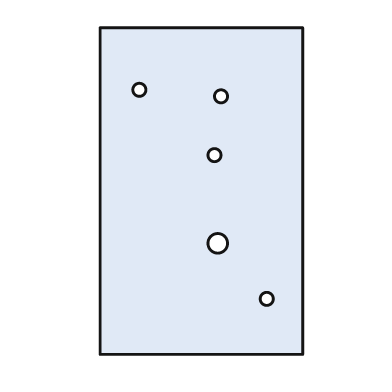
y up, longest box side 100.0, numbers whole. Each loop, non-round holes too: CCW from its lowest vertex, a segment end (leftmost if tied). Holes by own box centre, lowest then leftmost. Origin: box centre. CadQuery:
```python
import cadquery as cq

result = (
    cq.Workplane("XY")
    .moveTo(-31.0, -50.0)
    .lineTo(31.0, -50.0)
    .lineTo(31.0, 50.0)
    .lineTo(-31.0, 50.0)
    .close()
    .moveTo(20.0, -33.0)
    .circle(2.0)
    .moveTo(5.0, -16.0)
    .circle(3.0)
    .moveTo(4.0, 11.0)
    .circle(2.0)
    .moveTo(6.0, 29.0)
    .circle(2.0)
    .moveTo(-19.0, 31.0)
    .circle(2.0)
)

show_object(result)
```